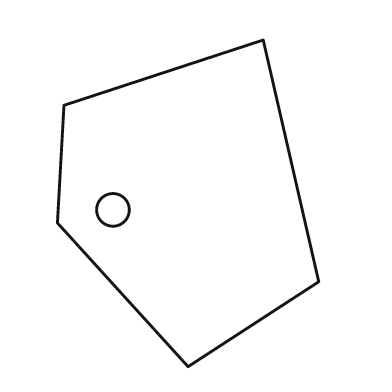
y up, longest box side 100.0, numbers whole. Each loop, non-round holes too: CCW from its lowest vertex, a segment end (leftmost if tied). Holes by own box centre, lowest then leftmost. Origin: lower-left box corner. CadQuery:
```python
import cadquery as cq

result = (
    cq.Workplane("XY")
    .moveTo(40.0, 0.0)
    .lineTo(80.0, 26.0)
    .lineTo(63.0, 100.0)
    .lineTo(2.0, 80.0)
    .lineTo(0.0, 44.0)
    .close()
    .moveTo(17.0, 48.0)
    .circle(5.0)
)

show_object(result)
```